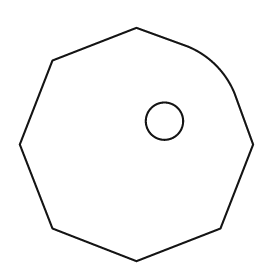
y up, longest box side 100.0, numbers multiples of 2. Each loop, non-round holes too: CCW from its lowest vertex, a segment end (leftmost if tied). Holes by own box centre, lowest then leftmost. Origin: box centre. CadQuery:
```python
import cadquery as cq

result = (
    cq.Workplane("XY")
    .moveTo(0.0, -50.0)
    .lineTo(36.0, -36.0)
    .lineTo(50.0, 0.0)
    .lineTo(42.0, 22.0)
    .threePointArc((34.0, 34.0), (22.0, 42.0))
    .lineTo(0.0, 50.0)
    .lineTo(-36.0, 36.0)
    .lineTo(-50.0, 0.0)
    .lineTo(-36.0, -36.0)
    .close()
    .moveTo(12.0, 10.0)
    .circle(8.0)
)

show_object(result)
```